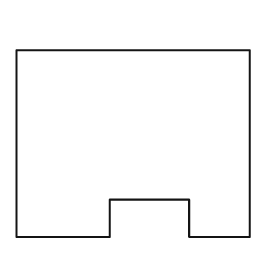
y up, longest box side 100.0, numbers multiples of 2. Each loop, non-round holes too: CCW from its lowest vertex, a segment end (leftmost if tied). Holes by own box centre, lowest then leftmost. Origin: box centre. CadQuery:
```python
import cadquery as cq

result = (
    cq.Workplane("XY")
    .moveTo(-50.0, -40.0)
    .lineTo(-10.0, -40.0)
    .lineTo(-10.0, -24.0)
    .lineTo(24.0, -24.0)
    .lineTo(24.0, -40.0)
    .lineTo(50.0, -40.0)
    .lineTo(50.0, 40.0)
    .lineTo(-50.0, 40.0)
    .close()
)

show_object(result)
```